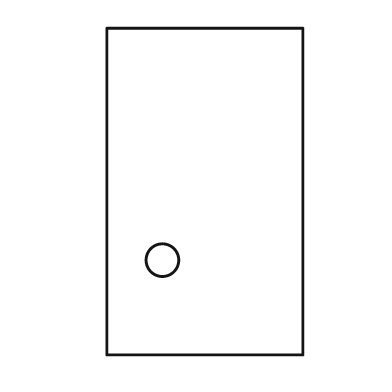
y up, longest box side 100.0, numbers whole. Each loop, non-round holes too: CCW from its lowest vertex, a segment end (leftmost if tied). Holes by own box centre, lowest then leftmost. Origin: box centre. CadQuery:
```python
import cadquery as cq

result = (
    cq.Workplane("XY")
    .moveTo(-30.0, -50.0)
    .lineTo(30.0, -50.0)
    .lineTo(30.0, 50.0)
    .lineTo(-30.0, 50.0)
    .close()
    .moveTo(-13.0, -21.0)
    .circle(5.0)
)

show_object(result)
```